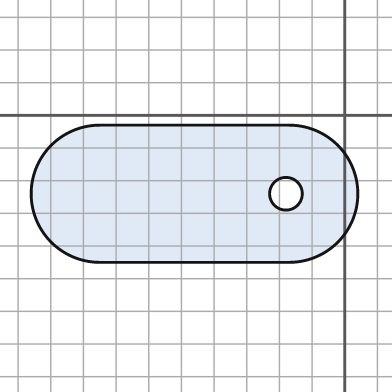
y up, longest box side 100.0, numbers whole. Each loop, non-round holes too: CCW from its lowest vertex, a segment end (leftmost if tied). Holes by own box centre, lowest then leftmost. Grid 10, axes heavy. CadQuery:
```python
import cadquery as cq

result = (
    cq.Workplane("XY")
    .moveTo(-75.0, -45.0)
    .lineTo(-17.0, -45.0)
    .threePointArc((4.0, -24.0), (-17.0, -3.0))
    .lineTo(-75.0, -3.0)
    .threePointArc((-96.0, -24.0), (-75.0, -45.0))
    .close()
    .moveTo(-18.0, -24.0)
    .circle(5.0)
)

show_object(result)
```